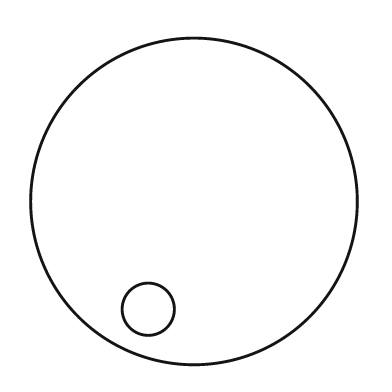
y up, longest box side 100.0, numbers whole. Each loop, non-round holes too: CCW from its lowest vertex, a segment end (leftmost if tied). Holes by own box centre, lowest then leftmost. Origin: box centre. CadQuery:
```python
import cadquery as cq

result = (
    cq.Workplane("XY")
    .moveTo(0.0, 0.0)
    .circle(50.0)
    .moveTo(-14.0, -33.0)
    .circle(8.0)
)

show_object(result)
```